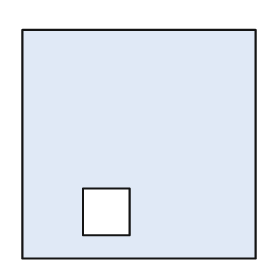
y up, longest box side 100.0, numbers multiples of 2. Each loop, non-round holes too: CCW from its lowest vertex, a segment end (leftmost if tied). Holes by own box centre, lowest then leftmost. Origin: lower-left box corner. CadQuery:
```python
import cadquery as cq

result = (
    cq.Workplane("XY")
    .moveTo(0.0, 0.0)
    .lineTo(100.0, 0.0)
    .lineTo(100.0, 98.0)
    .lineTo(0.0, 98.0)
    .close()
    .moveTo(26.0, 10.0)
    .lineTo(46.0, 10.0)
    .lineTo(46.0, 30.0)
    .lineTo(26.0, 30.0)
    .close()
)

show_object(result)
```